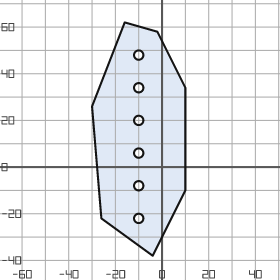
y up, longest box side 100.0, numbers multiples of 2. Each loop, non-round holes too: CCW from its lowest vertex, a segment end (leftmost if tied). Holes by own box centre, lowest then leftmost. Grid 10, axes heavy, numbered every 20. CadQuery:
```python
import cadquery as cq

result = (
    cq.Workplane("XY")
    .moveTo(-4.0, -38.0)
    .lineTo(10.0, -10.0)
    .lineTo(10.0, 34.0)
    .lineTo(-2.0, 58.0)
    .lineTo(-16.0, 62.0)
    .lineTo(-30.0, 26.0)
    .lineTo(-26.0, -22.0)
    .close()
    .moveTo(-10.0, -22.0)
    .circle(2.0)
    .moveTo(-10.0, -8.0)
    .circle(2.0)
    .moveTo(-10.0, 6.0)
    .circle(2.0)
    .moveTo(-10.0, 20.0)
    .circle(2.0)
    .moveTo(-10.0, 34.0)
    .circle(2.0)
    .moveTo(-10.0, 48.0)
    .circle(2.0)
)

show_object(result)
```